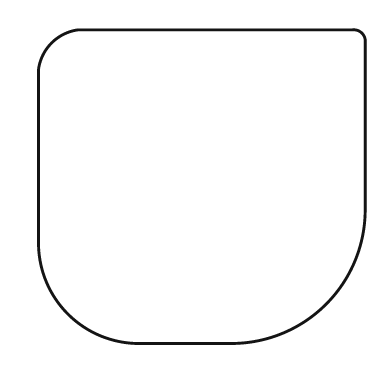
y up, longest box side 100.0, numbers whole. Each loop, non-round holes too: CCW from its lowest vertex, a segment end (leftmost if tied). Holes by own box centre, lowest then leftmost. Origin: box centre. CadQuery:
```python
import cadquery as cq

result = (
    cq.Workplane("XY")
    .moveTo(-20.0, -48.0)
    .lineTo(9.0, -48.0)
    .threePointArc((38.0, -36.0), (50.0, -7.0))
    .lineTo(50.0, 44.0)
    .threePointArc((49.0, 47.0), (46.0, 48.0))
    .lineTo(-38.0, 48.0)
    .threePointArc((-46.0, 44.0), (-50.0, 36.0))
    .lineTo(-50.0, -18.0)
    .threePointArc((-41.0, -39.0), (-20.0, -48.0))
    .close()
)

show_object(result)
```